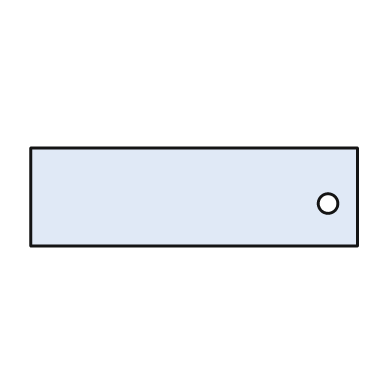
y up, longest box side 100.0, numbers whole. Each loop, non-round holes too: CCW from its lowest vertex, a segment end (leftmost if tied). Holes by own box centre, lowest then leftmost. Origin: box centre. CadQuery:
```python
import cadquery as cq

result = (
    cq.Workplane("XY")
    .moveTo(-50.0, -15.0)
    .lineTo(50.0, -15.0)
    .lineTo(50.0, 15.0)
    .lineTo(-50.0, 15.0)
    .close()
    .moveTo(41.0, -2.0)
    .circle(3.0)
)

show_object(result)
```